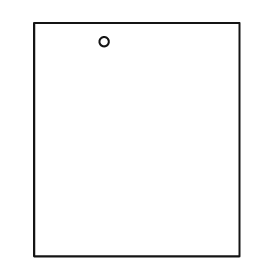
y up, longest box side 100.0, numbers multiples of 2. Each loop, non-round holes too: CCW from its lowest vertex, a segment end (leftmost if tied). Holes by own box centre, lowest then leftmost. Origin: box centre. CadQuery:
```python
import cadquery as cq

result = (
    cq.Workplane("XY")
    .moveTo(-44.0, -50.0)
    .lineTo(44.0, -50.0)
    .lineTo(44.0, 50.0)
    .lineTo(-44.0, 50.0)
    .close()
    .moveTo(-14.0, 42.0)
    .circle(2.0)
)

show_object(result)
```